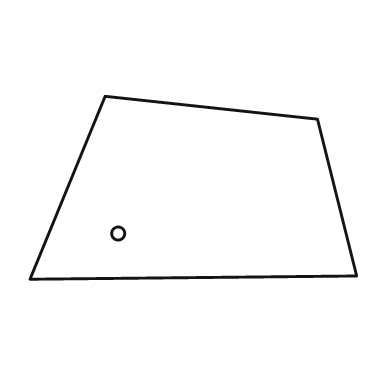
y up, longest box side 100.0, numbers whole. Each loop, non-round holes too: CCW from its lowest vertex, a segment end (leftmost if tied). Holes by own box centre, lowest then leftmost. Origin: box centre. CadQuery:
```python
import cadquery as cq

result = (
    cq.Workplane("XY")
    .moveTo(-50.0, -28.0)
    .lineTo(50.0, -27.0)
    .lineTo(38.0, 21.0)
    .lineTo(-27.0, 28.0)
    .close()
    .moveTo(-23.0, -14.0)
    .circle(2.0)
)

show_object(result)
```